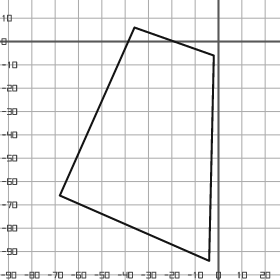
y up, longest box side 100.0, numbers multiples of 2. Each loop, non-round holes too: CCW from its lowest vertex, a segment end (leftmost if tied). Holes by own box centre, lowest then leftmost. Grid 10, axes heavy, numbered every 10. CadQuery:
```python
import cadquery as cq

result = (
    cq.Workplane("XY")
    .moveTo(-4.0, -94.0)
    .lineTo(-2.0, -6.0)
    .lineTo(-36.0, 6.0)
    .lineTo(-68.0, -66.0)
    .close()
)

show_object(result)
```